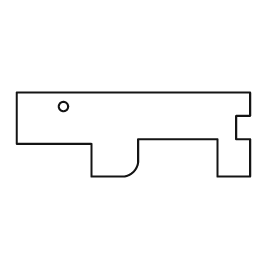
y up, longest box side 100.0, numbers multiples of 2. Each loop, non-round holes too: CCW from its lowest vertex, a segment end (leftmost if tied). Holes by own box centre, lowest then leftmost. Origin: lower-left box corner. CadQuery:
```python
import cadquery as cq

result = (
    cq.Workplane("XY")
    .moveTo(32.0, 0.0)
    .lineTo(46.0, 0.0)
    .threePointArc((50.0, 2.0), (52.0, 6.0))
    .lineTo(52.0, 16.0)
    .lineTo(86.0, 16.0)
    .lineTo(86.0, 0.0)
    .lineTo(100.0, 0.0)
    .lineTo(100.0, 16.0)
    .lineTo(94.0, 16.0)
    .lineTo(94.0, 26.0)
    .lineTo(100.0, 26.0)
    .lineTo(100.0, 36.0)
    .lineTo(0.0, 36.0)
    .lineTo(0.0, 14.0)
    .lineTo(32.0, 14.0)
    .close()
    .moveTo(20.0, 30.0)
    .circle(2.0)
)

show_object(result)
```